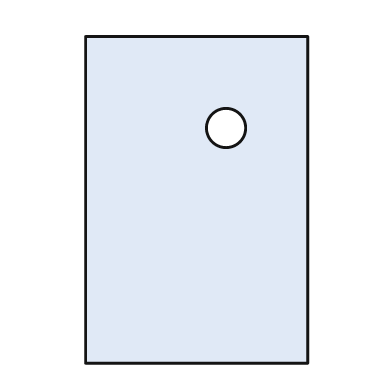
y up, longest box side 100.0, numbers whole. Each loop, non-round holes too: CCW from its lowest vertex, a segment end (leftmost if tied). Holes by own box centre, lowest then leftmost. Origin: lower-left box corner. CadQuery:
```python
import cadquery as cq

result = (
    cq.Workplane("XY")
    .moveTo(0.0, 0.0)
    .lineTo(68.0, 0.0)
    .lineTo(68.0, 100.0)
    .lineTo(0.0, 100.0)
    .close()
    .moveTo(43.0, 72.0)
    .circle(6.0)
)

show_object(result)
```